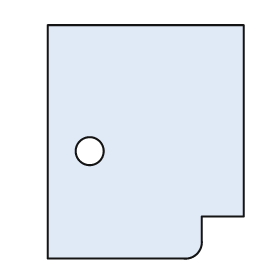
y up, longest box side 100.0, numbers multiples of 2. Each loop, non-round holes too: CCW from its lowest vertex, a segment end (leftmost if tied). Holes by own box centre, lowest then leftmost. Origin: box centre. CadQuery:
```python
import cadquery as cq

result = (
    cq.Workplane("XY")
    .moveTo(-42.0, -50.0)
    .lineTo(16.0, -50.0)
    .threePointArc((22.0, -48.0), (24.0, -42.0))
    .lineTo(24.0, -32.0)
    .lineTo(42.0, -32.0)
    .lineTo(42.0, 50.0)
    .lineTo(-42.0, 50.0)
    .close()
    .moveTo(-24.0, -4.0)
    .circle(6.0)
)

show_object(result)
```